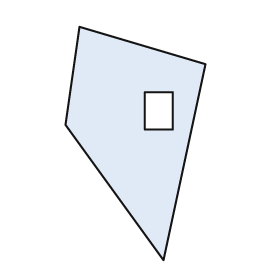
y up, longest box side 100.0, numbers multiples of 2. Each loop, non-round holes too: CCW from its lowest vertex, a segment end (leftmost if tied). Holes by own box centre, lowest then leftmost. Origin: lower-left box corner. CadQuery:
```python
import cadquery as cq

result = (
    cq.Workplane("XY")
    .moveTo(42.0, 0.0)
    .lineTo(60.0, 84.0)
    .lineTo(6.0, 100.0)
    .lineTo(0.0, 58.0)
    .close()
    .moveTo(34.0, 56.0)
    .lineTo(46.0, 56.0)
    .lineTo(46.0, 72.0)
    .lineTo(34.0, 72.0)
    .close()
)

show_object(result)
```